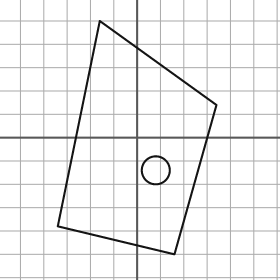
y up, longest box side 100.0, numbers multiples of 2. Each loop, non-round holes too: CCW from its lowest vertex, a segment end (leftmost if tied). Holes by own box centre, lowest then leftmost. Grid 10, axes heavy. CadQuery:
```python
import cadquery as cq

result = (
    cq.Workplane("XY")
    .moveTo(16.0, -50.0)
    .lineTo(34.0, 14.0)
    .lineTo(-16.0, 50.0)
    .lineTo(-34.0, -38.0)
    .close()
    .moveTo(8.0, -14.0)
    .circle(6.0)
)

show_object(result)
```